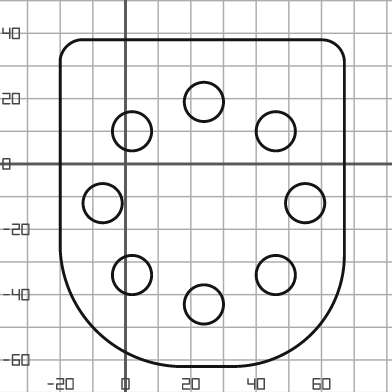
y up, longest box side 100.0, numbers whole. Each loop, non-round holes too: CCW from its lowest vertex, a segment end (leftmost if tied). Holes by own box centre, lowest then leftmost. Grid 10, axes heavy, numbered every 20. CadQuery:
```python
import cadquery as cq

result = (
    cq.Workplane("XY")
    .moveTo(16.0, -62.0)
    .lineTo(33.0, -62.0)
    .threePointArc((57.0, -52.0), (67.0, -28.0))
    .lineTo(67.0, 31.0)
    .threePointArc((65.0, 36.0), (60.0, 38.0))
    .lineTo(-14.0, 38.0)
    .threePointArc((-18.0, 36.0), (-20.0, 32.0))
    .lineTo(-20.0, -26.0)
    .threePointArc((-9.0, -51.0), (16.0, -62.0))
    .close()
    .moveTo(24.0, -43.0)
    .circle(6.0)
    .moveTo(2.0, -34.0)
    .circle(6.0)
    .moveTo(46.0, -34.0)
    .circle(6.0)
    .moveTo(-7.0, -12.0)
    .circle(6.0)
    .moveTo(55.0, -12.0)
    .circle(6.0)
    .moveTo(2.0, 10.0)
    .circle(6.0)
    .moveTo(46.0, 10.0)
    .circle(6.0)
    .moveTo(24.0, 19.0)
    .circle(6.0)
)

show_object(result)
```